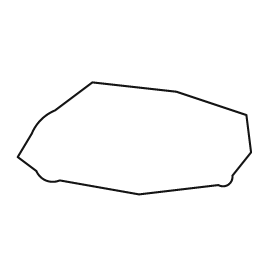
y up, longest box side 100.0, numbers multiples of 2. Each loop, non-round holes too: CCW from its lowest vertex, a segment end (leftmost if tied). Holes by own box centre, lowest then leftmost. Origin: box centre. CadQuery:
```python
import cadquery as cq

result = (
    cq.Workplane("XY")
    .moveTo(2.0, -24.0)
    .lineTo(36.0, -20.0)
    .threePointArc((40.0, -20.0), (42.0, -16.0))
    .lineTo(50.0, -6.0)
    .lineTo(48.0, 10.0)
    .lineTo(18.0, 20.0)
    .lineTo(-18.0, 24.0)
    .lineTo(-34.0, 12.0)
    .threePointArc((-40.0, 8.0), (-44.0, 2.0))
    .lineTo(-50.0, -8.0)
    .lineTo(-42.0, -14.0)
    .threePointArc((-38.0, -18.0), (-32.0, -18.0))
    .close()
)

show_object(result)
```